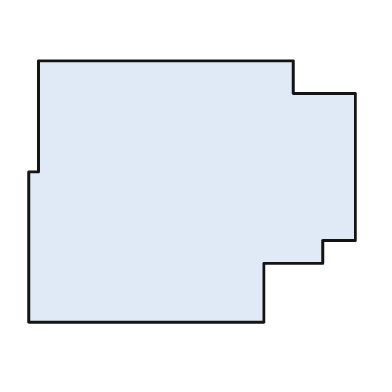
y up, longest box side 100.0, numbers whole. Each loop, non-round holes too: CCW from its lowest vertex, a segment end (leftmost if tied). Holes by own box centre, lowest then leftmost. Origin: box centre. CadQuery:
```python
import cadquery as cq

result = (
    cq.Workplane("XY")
    .moveTo(-50.0, -40.0)
    .lineTo(22.0, -40.0)
    .lineTo(22.0, -22.0)
    .lineTo(40.0, -22.0)
    .lineTo(40.0, -15.0)
    .lineTo(50.0, -15.0)
    .lineTo(50.0, 30.0)
    .lineTo(31.0, 30.0)
    .lineTo(31.0, 40.0)
    .lineTo(-47.0, 40.0)
    .lineTo(-47.0, 6.0)
    .lineTo(-50.0, 6.0)
    .close()
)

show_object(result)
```